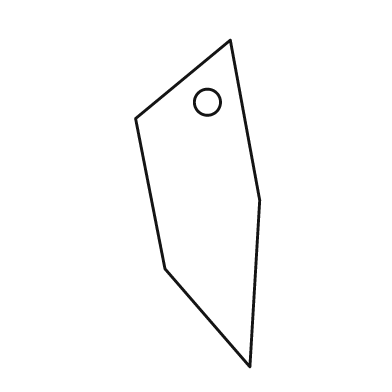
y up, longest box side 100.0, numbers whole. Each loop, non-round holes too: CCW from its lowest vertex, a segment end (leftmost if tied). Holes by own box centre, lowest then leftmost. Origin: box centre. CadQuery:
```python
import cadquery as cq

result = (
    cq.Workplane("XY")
    .moveTo(16.0, -50.0)
    .lineTo(19.0, 1.0)
    .lineTo(10.0, 50.0)
    .lineTo(-19.0, 26.0)
    .lineTo(-10.0, -20.0)
    .close()
    .moveTo(3.0, 31.0)
    .circle(4.0)
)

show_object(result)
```